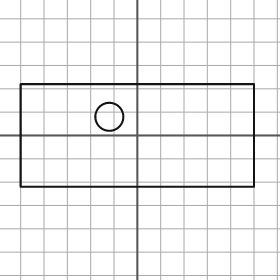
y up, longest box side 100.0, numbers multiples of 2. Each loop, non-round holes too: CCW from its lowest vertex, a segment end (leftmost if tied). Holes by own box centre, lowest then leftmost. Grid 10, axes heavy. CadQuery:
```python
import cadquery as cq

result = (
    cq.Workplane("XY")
    .moveTo(-50.0, -22.0)
    .lineTo(50.0, -22.0)
    .lineTo(50.0, 22.0)
    .lineTo(-50.0, 22.0)
    .close()
    .moveTo(-12.0, 8.0)
    .circle(6.0)
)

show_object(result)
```